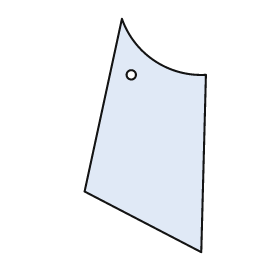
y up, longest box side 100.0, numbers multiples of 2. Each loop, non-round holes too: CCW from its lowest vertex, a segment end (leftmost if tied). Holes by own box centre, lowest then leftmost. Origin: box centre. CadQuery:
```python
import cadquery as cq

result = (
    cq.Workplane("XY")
    .moveTo(24.0, -50.0)
    .lineTo(26.0, 26.0)
    .threePointArc((4.0, 32.0), (-10.0, 50.0))
    .lineTo(-26.0, -24.0)
    .close()
    .moveTo(-6.0, 26.0)
    .circle(2.0)
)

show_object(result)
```